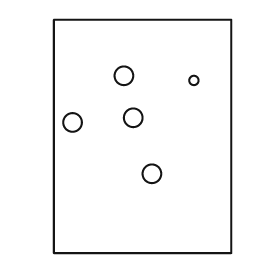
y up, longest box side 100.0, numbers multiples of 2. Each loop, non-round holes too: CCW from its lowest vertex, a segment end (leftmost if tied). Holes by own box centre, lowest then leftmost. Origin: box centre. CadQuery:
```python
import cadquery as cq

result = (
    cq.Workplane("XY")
    .moveTo(-38.0, -50.0)
    .lineTo(38.0, -50.0)
    .lineTo(38.0, 50.0)
    .lineTo(-38.0, 50.0)
    .close()
    .moveTo(4.0, -16.0)
    .circle(4.0)
    .moveTo(-30.0, 6.0)
    .circle(4.0)
    .moveTo(-4.0, 8.0)
    .circle(4.0)
    .moveTo(22.0, 24.0)
    .circle(2.0)
    .moveTo(-8.0, 26.0)
    .circle(4.0)
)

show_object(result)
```